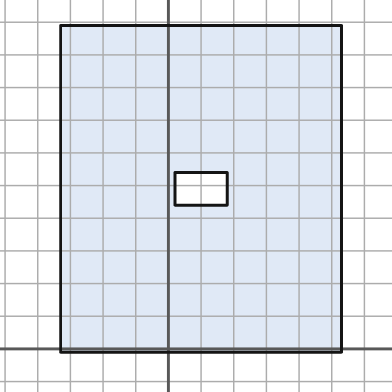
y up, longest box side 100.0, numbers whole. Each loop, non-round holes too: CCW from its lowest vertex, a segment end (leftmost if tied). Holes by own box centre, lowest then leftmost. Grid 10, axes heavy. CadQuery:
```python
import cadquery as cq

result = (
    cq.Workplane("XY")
    .moveTo(-33.0, -1.0)
    .lineTo(53.0, -1.0)
    .lineTo(53.0, 99.0)
    .lineTo(-33.0, 99.0)
    .close()
    .moveTo(2.0, 44.0)
    .lineTo(18.0, 44.0)
    .lineTo(18.0, 54.0)
    .lineTo(2.0, 54.0)
    .close()
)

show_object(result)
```